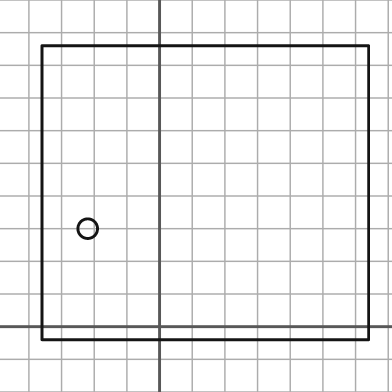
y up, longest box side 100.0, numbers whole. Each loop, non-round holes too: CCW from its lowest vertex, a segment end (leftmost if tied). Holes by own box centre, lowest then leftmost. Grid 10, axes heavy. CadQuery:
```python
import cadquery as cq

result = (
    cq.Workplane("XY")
    .moveTo(-36.0, -4.0)
    .lineTo(64.0, -4.0)
    .lineTo(64.0, 86.0)
    .lineTo(-36.0, 86.0)
    .close()
    .moveTo(-22.0, 30.0)
    .circle(3.0)
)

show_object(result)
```